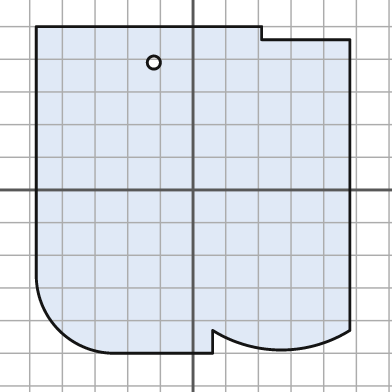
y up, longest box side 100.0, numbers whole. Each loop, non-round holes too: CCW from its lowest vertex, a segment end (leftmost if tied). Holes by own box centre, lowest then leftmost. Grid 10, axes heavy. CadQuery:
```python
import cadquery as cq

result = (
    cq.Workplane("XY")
    .moveTo(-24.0, -50.0)
    .lineTo(6.0, -50.0)
    .lineTo(6.0, -43.0)
    .threePointArc((27.0, -49.0), (48.0, -43.0))
    .lineTo(48.0, 46.0)
    .lineTo(21.0, 46.0)
    .lineTo(21.0, 50.0)
    .lineTo(-48.0, 50.0)
    .lineTo(-48.0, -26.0)
    .threePointArc((-41.0, -43.0), (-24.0, -50.0))
    .close()
    .moveTo(-12.0, 39.0)
    .circle(2.0)
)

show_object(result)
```